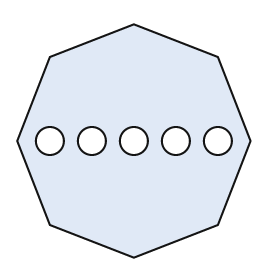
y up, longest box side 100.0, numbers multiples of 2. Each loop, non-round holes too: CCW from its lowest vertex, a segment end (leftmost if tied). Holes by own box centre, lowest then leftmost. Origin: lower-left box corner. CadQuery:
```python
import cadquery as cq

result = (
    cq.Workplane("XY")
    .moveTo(50.0, 0.0)
    .lineTo(86.0, 14.0)
    .lineTo(100.0, 50.0)
    .lineTo(86.0, 86.0)
    .lineTo(50.0, 100.0)
    .lineTo(14.0, 86.0)
    .lineTo(0.0, 50.0)
    .lineTo(14.0, 14.0)
    .close()
    .moveTo(14.0, 50.0)
    .circle(6.0)
    .moveTo(32.0, 50.0)
    .circle(6.0)
    .moveTo(50.0, 50.0)
    .circle(6.0)
    .moveTo(68.0, 50.0)
    .circle(6.0)
    .moveTo(86.0, 50.0)
    .circle(6.0)
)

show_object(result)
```